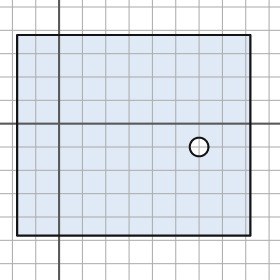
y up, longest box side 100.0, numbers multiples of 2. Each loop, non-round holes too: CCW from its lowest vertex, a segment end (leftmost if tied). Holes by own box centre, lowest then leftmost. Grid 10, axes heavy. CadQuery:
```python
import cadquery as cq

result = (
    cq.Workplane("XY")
    .moveTo(-18.0, -48.0)
    .lineTo(82.0, -48.0)
    .lineTo(82.0, 38.0)
    .lineTo(-18.0, 38.0)
    .close()
    .moveTo(60.0, -10.0)
    .circle(4.0)
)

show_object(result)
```